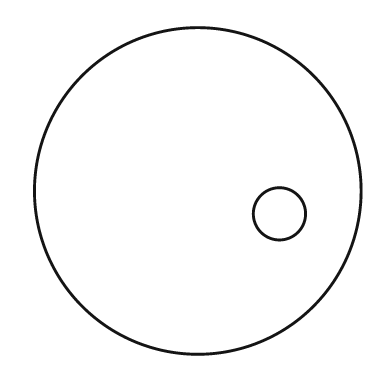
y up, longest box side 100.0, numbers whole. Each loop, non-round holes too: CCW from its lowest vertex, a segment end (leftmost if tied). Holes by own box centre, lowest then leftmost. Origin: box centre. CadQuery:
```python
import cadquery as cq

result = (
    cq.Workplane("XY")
    .moveTo(0.0, 0.0)
    .circle(50.0)
    .moveTo(25.0, -7.0)
    .circle(8.0)
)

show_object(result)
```